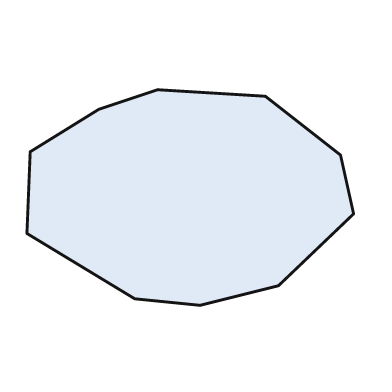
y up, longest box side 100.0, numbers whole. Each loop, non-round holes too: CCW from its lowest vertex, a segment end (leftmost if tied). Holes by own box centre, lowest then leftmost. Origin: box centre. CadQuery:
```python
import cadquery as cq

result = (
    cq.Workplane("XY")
    .moveTo(3.0, -33.0)
    .lineTo(27.0, -27.0)
    .lineTo(50.0, -5.0)
    .lineTo(46.0, 13.0)
    .lineTo(23.0, 31.0)
    .lineTo(-10.0, 33.0)
    .lineTo(-28.0, 27.0)
    .lineTo(-49.0, 14.0)
    .lineTo(-50.0, -11.0)
    .lineTo(-17.0, -31.0)
    .close()
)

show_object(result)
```